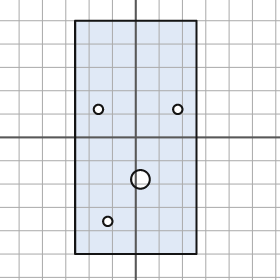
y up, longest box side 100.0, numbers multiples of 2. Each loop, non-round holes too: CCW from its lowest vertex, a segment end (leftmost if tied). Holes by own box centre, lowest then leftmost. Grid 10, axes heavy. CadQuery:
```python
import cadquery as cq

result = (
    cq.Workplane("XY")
    .moveTo(-26.0, -50.0)
    .lineTo(26.0, -50.0)
    .lineTo(26.0, 50.0)
    .lineTo(-26.0, 50.0)
    .close()
    .moveTo(-12.0, -36.0)
    .circle(2.0)
    .moveTo(2.0, -18.0)
    .circle(4.0)
    .moveTo(-16.0, 12.0)
    .circle(2.0)
    .moveTo(18.0, 12.0)
    .circle(2.0)
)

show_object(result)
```